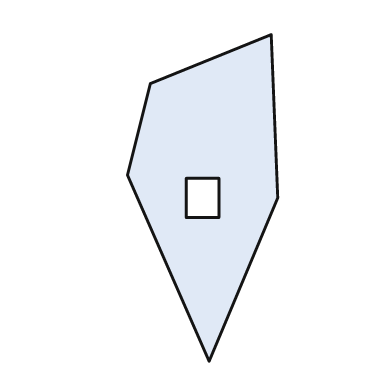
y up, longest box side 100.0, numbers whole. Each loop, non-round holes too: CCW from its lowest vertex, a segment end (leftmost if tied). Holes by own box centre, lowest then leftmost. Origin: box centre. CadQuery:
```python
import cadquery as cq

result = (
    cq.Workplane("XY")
    .moveTo(2.0, -50.0)
    .lineTo(23.0, 0.0)
    .lineTo(21.0, 50.0)
    .lineTo(-16.0, 35.0)
    .lineTo(-23.0, 7.0)
    .close()
    .moveTo(-5.0, -6.0)
    .lineTo(5.0, -6.0)
    .lineTo(5.0, 6.0)
    .lineTo(-5.0, 6.0)
    .close()
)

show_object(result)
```